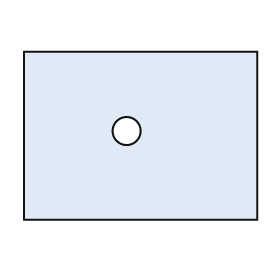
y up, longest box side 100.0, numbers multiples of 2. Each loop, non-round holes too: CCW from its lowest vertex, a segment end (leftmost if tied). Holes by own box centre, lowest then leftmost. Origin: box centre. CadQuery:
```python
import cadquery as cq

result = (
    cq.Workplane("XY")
    .moveTo(-50.0, -36.0)
    .lineTo(50.0, -36.0)
    .lineTo(50.0, 36.0)
    .lineTo(-50.0, 36.0)
    .close()
    .moveTo(-6.0, 2.0)
    .circle(6.0)
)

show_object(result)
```